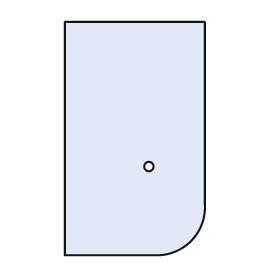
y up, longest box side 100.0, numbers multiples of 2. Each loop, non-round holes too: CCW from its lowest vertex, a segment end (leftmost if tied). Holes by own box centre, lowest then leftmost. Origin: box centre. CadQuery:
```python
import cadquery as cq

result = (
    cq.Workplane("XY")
    .moveTo(-30.0, -50.0)
    .lineTo(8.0, -50.0)
    .threePointArc((24.0, -44.0), (30.0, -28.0))
    .lineTo(30.0, 50.0)
    .lineTo(-30.0, 50.0)
    .close()
    .moveTo(6.0, -12.0)
    .circle(2.0)
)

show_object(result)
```